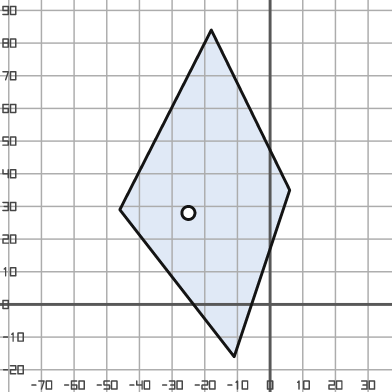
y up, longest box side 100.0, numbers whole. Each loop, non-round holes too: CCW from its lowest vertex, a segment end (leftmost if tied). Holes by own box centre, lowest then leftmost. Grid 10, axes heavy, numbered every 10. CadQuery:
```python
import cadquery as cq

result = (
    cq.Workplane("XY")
    .moveTo(-11.0, -16.0)
    .lineTo(6.0, 35.0)
    .lineTo(-18.0, 84.0)
    .lineTo(-46.0, 29.0)
    .close()
    .moveTo(-25.0, 28.0)
    .circle(2.0)
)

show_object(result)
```